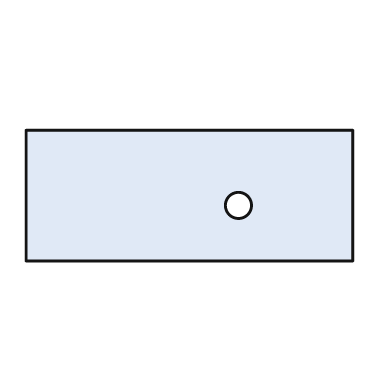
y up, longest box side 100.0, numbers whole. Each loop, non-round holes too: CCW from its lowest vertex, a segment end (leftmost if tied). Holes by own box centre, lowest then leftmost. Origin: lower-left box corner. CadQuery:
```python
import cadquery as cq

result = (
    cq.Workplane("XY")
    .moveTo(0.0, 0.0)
    .lineTo(100.0, 0.0)
    .lineTo(100.0, 40.0)
    .lineTo(0.0, 40.0)
    .close()
    .moveTo(65.0, 17.0)
    .circle(4.0)
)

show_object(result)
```